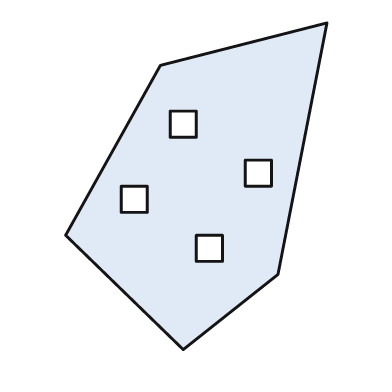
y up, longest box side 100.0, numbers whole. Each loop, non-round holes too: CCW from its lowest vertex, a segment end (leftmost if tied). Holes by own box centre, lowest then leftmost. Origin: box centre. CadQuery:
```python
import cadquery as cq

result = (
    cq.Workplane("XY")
    .moveTo(-4.0, -50.0)
    .lineTo(25.0, -27.0)
    .lineTo(40.0, 50.0)
    .lineTo(-11.0, 37.0)
    .lineTo(-40.0, -15.0)
    .close()
    .moveTo(0.0, -23.0)
    .lineTo(8.0, -23.0)
    .lineTo(8.0, -15.0)
    .lineTo(0.0, -15.0)
    .close()
    .moveTo(-23.0, -8.0)
    .lineTo(-15.0, -8.0)
    .lineTo(-15.0, 0.0)
    .lineTo(-23.0, 0.0)
    .close()
    .moveTo(15.0, 0.0)
    .lineTo(23.0, 0.0)
    .lineTo(23.0, 8.0)
    .lineTo(15.0, 8.0)
    .close()
    .moveTo(-8.0, 15.0)
    .lineTo(0.0, 15.0)
    .lineTo(0.0, 23.0)
    .lineTo(-8.0, 23.0)
    .close()
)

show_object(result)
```